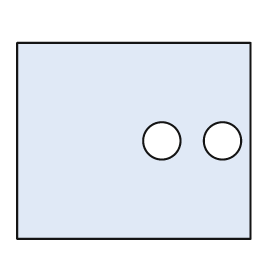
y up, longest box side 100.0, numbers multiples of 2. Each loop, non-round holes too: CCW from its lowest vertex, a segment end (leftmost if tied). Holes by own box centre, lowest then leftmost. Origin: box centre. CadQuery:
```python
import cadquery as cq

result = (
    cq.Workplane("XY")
    .moveTo(-50.0, -42.0)
    .lineTo(50.0, -42.0)
    .lineTo(50.0, 42.0)
    .lineTo(-50.0, 42.0)
    .close()
    .moveTo(12.0, 0.0)
    .circle(8.0)
    .moveTo(38.0, 0.0)
    .circle(8.0)
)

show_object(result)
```